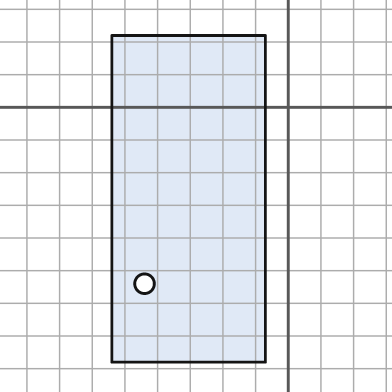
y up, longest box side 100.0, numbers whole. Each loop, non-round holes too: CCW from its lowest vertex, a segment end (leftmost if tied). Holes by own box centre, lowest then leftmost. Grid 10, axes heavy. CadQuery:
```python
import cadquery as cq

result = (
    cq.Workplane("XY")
    .moveTo(-54.0, -78.0)
    .lineTo(-7.0, -78.0)
    .lineTo(-7.0, 22.0)
    .lineTo(-54.0, 22.0)
    .close()
    .moveTo(-44.0, -54.0)
    .circle(3.0)
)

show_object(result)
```